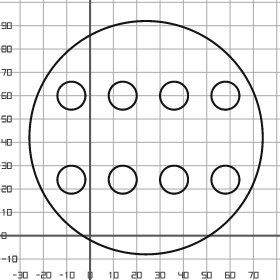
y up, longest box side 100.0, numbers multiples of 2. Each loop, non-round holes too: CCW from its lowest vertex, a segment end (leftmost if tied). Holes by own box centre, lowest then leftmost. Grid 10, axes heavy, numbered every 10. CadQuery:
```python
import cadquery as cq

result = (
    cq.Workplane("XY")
    .moveTo(24.0, 42.0)
    .circle(50.0)
    .moveTo(-8.0, 24.0)
    .circle(6.0)
    .moveTo(14.0, 24.0)
    .circle(6.0)
    .moveTo(36.0, 24.0)
    .circle(6.0)
    .moveTo(58.0, 24.0)
    .circle(6.0)
    .moveTo(-8.0, 60.0)
    .circle(6.0)
    .moveTo(14.0, 60.0)
    .circle(6.0)
    .moveTo(36.0, 60.0)
    .circle(6.0)
    .moveTo(58.0, 60.0)
    .circle(6.0)
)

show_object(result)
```